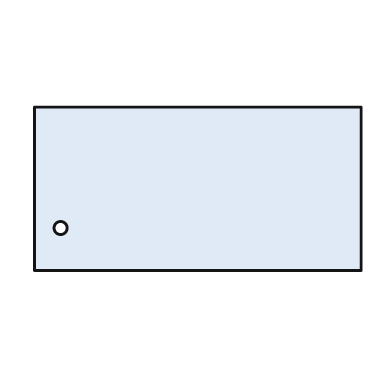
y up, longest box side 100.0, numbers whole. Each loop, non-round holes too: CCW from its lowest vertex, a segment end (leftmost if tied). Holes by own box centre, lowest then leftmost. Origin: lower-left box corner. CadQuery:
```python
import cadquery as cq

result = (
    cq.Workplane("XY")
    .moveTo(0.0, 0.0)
    .lineTo(100.0, 0.0)
    .lineTo(100.0, 50.0)
    .lineTo(0.0, 50.0)
    .close()
    .moveTo(8.0, 13.0)
    .circle(2.0)
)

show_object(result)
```